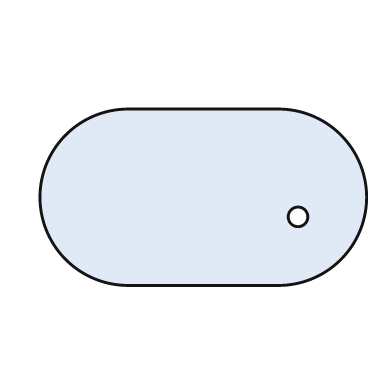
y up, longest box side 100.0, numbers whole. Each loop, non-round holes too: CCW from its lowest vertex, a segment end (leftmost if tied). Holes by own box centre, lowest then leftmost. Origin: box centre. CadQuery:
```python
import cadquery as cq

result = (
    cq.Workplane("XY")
    .moveTo(-23.0, -27.0)
    .lineTo(23.0, -27.0)
    .threePointArc((50.0, 0.0), (23.0, 27.0))
    .lineTo(-23.0, 27.0)
    .threePointArc((-50.0, 0.0), (-23.0, -27.0))
    .close()
    .moveTo(29.0, -6.0)
    .circle(3.0)
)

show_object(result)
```